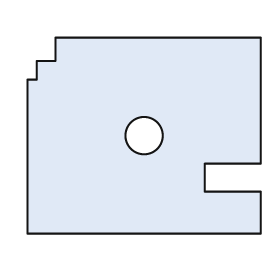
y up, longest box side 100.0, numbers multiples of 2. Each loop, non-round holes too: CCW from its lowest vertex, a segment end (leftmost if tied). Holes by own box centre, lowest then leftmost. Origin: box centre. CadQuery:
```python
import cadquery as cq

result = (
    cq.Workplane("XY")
    .moveTo(-50.0, -42.0)
    .lineTo(50.0, -42.0)
    .lineTo(50.0, -24.0)
    .lineTo(26.0, -24.0)
    .lineTo(26.0, -12.0)
    .lineTo(50.0, -12.0)
    .lineTo(50.0, 42.0)
    .lineTo(-38.0, 42.0)
    .lineTo(-38.0, 32.0)
    .lineTo(-46.0, 32.0)
    .lineTo(-46.0, 24.0)
    .lineTo(-50.0, 24.0)
    .close()
    .moveTo(0.0, 0.0)
    .circle(8.0)
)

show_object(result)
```